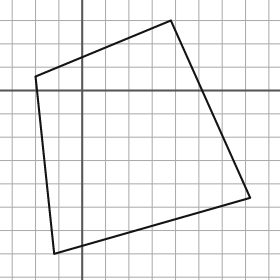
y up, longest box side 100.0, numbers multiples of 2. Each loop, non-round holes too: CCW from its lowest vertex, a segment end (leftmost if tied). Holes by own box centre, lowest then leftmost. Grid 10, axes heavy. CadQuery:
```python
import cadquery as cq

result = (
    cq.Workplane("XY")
    .moveTo(-12.0, -70.0)
    .lineTo(72.0, -46.0)
    .lineTo(38.0, 30.0)
    .lineTo(-20.0, 6.0)
    .close()
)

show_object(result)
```